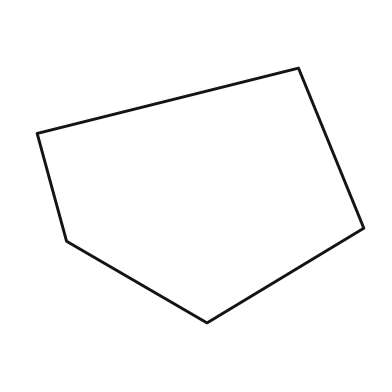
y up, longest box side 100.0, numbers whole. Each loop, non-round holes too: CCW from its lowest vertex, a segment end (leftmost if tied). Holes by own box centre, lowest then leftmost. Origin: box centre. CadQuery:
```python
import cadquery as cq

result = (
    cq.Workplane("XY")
    .moveTo(2.0, -39.0)
    .lineTo(50.0, -10.0)
    .lineTo(30.0, 39.0)
    .lineTo(-50.0, 19.0)
    .lineTo(-41.0, -14.0)
    .close()
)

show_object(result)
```